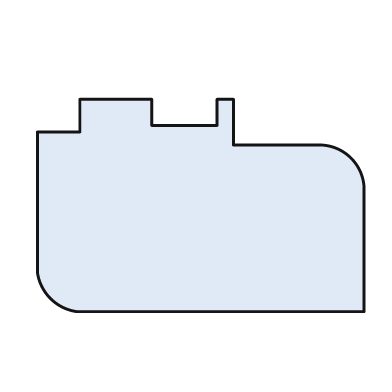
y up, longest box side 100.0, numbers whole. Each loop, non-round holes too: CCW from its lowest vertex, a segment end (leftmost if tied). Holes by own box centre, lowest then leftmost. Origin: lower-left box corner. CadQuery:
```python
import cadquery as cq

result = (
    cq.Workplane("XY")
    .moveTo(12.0, 0.0)
    .lineTo(100.0, 0.0)
    .lineTo(100.0, 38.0)
    .threePointArc((96.0, 47.0), (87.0, 51.0))
    .lineTo(60.0, 51.0)
    .lineTo(60.0, 65.0)
    .lineTo(55.0, 65.0)
    .lineTo(55.0, 57.0)
    .lineTo(35.0, 57.0)
    .lineTo(35.0, 65.0)
    .lineTo(13.0, 65.0)
    .lineTo(13.0, 55.0)
    .lineTo(0.0, 55.0)
    .lineTo(0.0, 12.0)
    .threePointArc((4.0, 4.0), (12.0, 0.0))
    .close()
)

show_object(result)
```